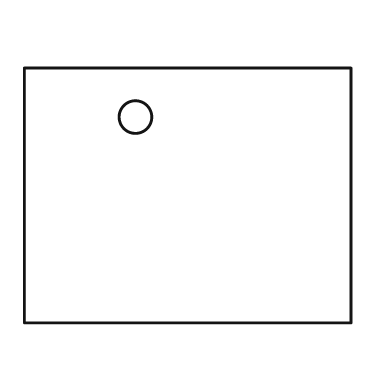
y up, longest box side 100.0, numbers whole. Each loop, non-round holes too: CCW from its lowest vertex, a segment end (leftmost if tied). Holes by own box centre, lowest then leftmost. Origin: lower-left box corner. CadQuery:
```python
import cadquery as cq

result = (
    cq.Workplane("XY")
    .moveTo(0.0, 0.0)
    .lineTo(100.0, 0.0)
    .lineTo(100.0, 78.0)
    .lineTo(0.0, 78.0)
    .close()
    .moveTo(34.0, 63.0)
    .circle(5.0)
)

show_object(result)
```